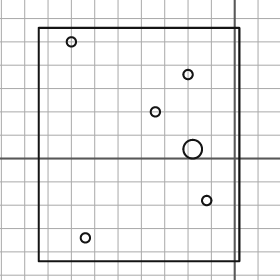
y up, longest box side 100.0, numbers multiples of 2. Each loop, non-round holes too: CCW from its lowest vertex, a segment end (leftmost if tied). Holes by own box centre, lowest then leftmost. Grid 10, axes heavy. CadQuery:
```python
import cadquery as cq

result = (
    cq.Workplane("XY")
    .moveTo(-84.0, -44.0)
    .lineTo(2.0, -44.0)
    .lineTo(2.0, 56.0)
    .lineTo(-84.0, 56.0)
    .close()
    .moveTo(-64.0, -34.0)
    .circle(2.0)
    .moveTo(-12.0, -18.0)
    .circle(2.0)
    .moveTo(-18.0, 4.0)
    .circle(4.0)
    .moveTo(-34.0, 20.0)
    .circle(2.0)
    .moveTo(-20.0, 36.0)
    .circle(2.0)
    .moveTo(-70.0, 50.0)
    .circle(2.0)
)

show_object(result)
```